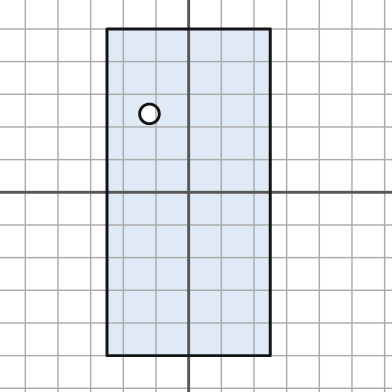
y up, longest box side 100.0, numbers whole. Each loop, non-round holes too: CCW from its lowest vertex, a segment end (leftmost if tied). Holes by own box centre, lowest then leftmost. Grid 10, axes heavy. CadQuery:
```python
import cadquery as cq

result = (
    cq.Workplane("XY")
    .moveTo(-25.0, -50.0)
    .lineTo(25.0, -50.0)
    .lineTo(25.0, 50.0)
    .lineTo(-25.0, 50.0)
    .close()
    .moveTo(-12.0, 24.0)
    .circle(3.0)
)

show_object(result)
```